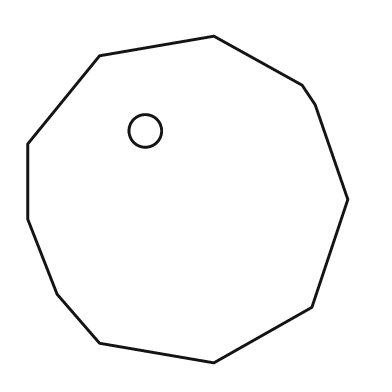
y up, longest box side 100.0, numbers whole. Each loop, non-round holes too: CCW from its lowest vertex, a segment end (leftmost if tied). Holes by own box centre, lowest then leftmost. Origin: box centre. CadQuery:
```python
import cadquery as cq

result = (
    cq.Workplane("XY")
    .moveTo(8.0, -50.0)
    .lineTo(38.0, -33.0)
    .lineTo(49.0, 0.0)
    .lineTo(39.0, 29.0)
    .lineTo(35.0, 35.0)
    .lineTo(8.0, 50.0)
    .lineTo(-27.0, 44.0)
    .lineTo(-49.0, 17.0)
    .lineTo(-49.0, -6.0)
    .lineTo(-40.0, -29.0)
    .lineTo(-27.0, -44.0)
    .close()
    .moveTo(-13.0, 21.0)
    .circle(5.0)
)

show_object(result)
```